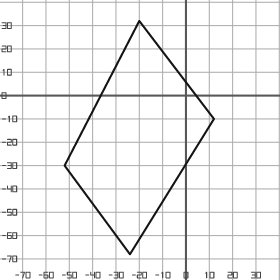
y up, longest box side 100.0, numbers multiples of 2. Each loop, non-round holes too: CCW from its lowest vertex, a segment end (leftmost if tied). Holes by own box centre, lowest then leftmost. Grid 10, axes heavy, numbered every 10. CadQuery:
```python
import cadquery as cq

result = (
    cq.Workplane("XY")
    .moveTo(-24.0, -68.0)
    .lineTo(12.0, -10.0)
    .lineTo(-20.0, 32.0)
    .lineTo(-52.0, -30.0)
    .close()
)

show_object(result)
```